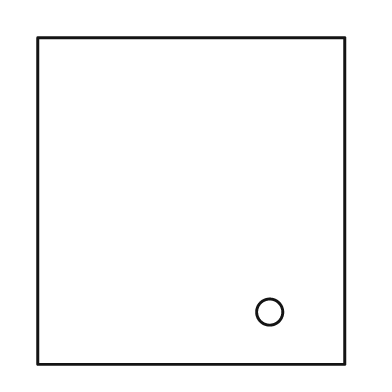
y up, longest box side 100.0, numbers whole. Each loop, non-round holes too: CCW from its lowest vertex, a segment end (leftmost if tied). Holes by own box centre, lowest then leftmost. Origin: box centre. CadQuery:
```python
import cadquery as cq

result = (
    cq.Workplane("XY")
    .moveTo(-47.0, -50.0)
    .lineTo(47.0, -50.0)
    .lineTo(47.0, 50.0)
    .lineTo(-47.0, 50.0)
    .close()
    .moveTo(24.0, -34.0)
    .circle(4.0)
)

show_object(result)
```